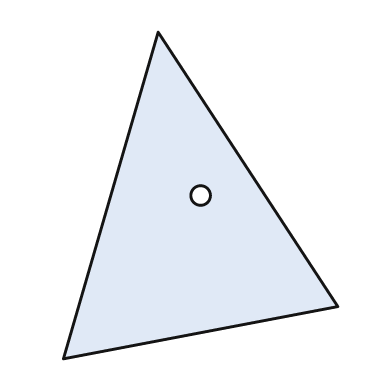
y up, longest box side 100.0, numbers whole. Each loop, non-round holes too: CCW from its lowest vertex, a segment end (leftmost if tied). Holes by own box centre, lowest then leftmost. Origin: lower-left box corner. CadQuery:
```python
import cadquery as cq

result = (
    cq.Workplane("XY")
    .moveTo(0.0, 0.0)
    .lineTo(84.0, 16.0)
    .lineTo(29.0, 100.0)
    .close()
    .moveTo(42.0, 50.0)
    .circle(3.0)
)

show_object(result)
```